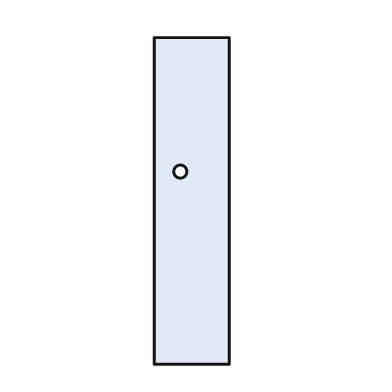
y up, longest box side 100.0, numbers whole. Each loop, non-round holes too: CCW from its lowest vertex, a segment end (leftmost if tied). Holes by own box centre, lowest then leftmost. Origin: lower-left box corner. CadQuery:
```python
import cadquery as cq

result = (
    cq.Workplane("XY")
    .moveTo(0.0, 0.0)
    .lineTo(23.0, 0.0)
    .lineTo(23.0, 100.0)
    .lineTo(0.0, 100.0)
    .close()
    .moveTo(8.0, 59.0)
    .circle(2.0)
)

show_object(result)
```